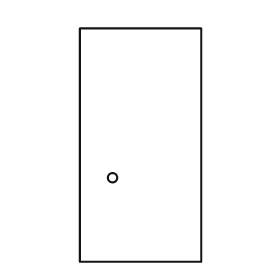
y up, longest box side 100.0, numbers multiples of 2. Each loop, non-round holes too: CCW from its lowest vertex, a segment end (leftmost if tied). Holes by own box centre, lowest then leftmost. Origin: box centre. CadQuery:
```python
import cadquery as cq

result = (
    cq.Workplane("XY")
    .moveTo(-26.0, -50.0)
    .lineTo(26.0, -50.0)
    .lineTo(26.0, 50.0)
    .lineTo(-26.0, 50.0)
    .close()
    .moveTo(-12.0, -14.0)
    .circle(2.0)
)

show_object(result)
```